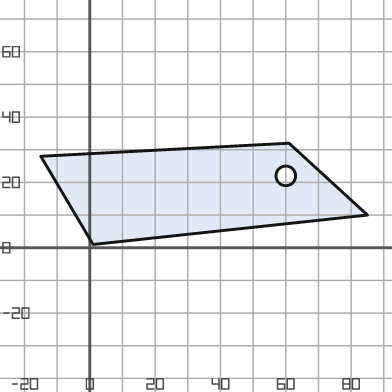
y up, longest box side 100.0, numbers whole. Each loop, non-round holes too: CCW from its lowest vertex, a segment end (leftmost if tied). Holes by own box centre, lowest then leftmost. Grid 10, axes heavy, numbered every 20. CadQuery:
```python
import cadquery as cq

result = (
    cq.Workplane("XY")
    .moveTo(1.0, 1.0)
    .lineTo(85.0, 10.0)
    .lineTo(61.0, 32.0)
    .lineTo(-15.0, 28.0)
    .close()
    .moveTo(60.0, 22.0)
    .circle(3.0)
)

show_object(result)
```